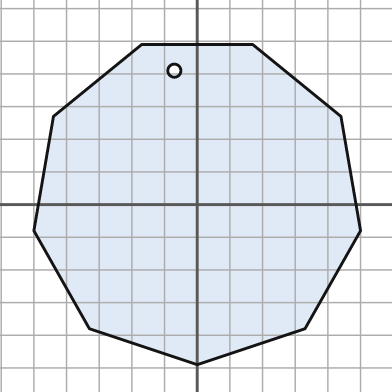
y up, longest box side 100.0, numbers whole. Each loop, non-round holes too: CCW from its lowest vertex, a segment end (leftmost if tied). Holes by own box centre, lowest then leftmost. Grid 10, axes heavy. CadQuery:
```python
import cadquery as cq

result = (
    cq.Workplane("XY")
    .moveTo(0.0, -49.0)
    .lineTo(33.0, -38.0)
    .lineTo(50.0, -8.0)
    .lineTo(44.0, 27.0)
    .lineTo(17.0, 49.0)
    .lineTo(-17.0, 49.0)
    .lineTo(-44.0, 27.0)
    .lineTo(-50.0, -8.0)
    .lineTo(-33.0, -38.0)
    .close()
    .moveTo(-7.0, 41.0)
    .circle(2.0)
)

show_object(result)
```